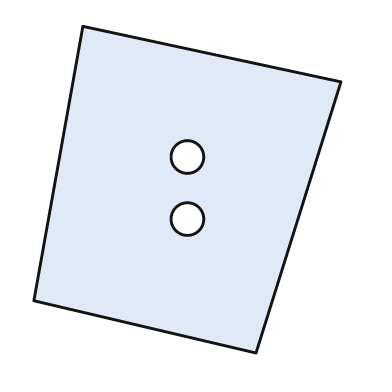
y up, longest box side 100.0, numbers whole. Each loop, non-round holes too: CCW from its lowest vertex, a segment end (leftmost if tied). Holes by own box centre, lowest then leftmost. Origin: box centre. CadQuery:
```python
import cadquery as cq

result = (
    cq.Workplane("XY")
    .moveTo(21.0, -50.0)
    .lineTo(47.0, 33.0)
    .lineTo(-32.0, 50.0)
    .lineTo(-47.0, -34.0)
    .close()
    .moveTo(0.0, -9.0)
    .circle(5.0)
    .moveTo(0.0, 10.0)
    .circle(5.0)
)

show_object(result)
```